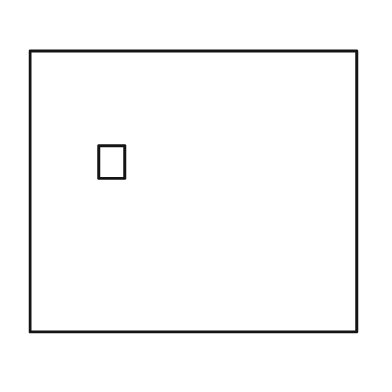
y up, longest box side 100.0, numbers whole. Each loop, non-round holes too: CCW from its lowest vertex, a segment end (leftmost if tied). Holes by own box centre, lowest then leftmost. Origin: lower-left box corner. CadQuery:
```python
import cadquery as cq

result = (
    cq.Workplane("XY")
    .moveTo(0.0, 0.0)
    .lineTo(100.0, 0.0)
    .lineTo(100.0, 86.0)
    .lineTo(0.0, 86.0)
    .close()
    .moveTo(21.0, 47.0)
    .lineTo(29.0, 47.0)
    .lineTo(29.0, 57.0)
    .lineTo(21.0, 57.0)
    .close()
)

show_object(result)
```